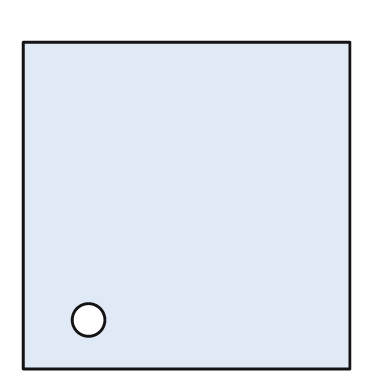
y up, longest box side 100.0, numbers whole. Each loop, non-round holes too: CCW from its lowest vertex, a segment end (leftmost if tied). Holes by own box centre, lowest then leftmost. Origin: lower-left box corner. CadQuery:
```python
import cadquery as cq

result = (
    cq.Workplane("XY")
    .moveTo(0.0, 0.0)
    .lineTo(100.0, 0.0)
    .lineTo(100.0, 100.0)
    .lineTo(0.0, 100.0)
    .close()
    .moveTo(20.0, 15.0)
    .circle(5.0)
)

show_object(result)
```